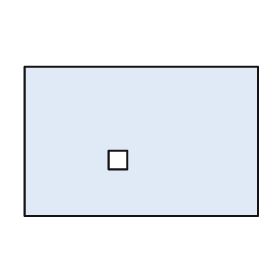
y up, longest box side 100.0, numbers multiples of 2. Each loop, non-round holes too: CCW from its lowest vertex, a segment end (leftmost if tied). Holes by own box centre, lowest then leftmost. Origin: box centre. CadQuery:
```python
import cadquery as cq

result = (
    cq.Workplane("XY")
    .moveTo(-50.0, -32.0)
    .lineTo(50.0, -32.0)
    .lineTo(50.0, 32.0)
    .lineTo(-50.0, 32.0)
    .close()
    .moveTo(-14.0, -12.0)
    .lineTo(-6.0, -12.0)
    .lineTo(-6.0, -4.0)
    .lineTo(-14.0, -4.0)
    .close()
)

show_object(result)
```